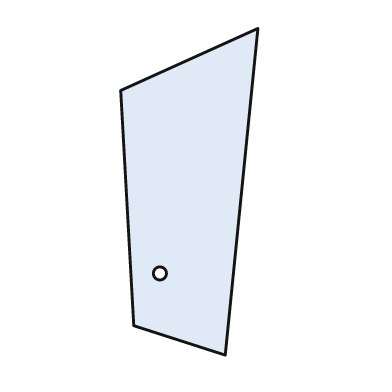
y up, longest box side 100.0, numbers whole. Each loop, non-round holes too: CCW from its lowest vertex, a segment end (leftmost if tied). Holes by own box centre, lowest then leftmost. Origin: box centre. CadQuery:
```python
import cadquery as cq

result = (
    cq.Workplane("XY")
    .moveTo(11.0, -50.0)
    .lineTo(21.0, 50.0)
    .lineTo(-21.0, 31.0)
    .lineTo(-17.0, -41.0)
    .close()
    .moveTo(-9.0, -25.0)
    .circle(2.0)
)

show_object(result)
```